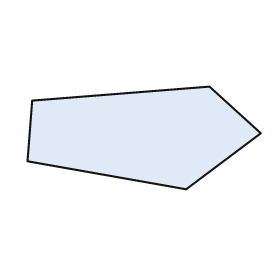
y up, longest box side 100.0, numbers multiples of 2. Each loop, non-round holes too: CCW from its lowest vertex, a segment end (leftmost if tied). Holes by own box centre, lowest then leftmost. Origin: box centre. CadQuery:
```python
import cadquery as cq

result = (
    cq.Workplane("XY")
    .moveTo(18.0, -22.0)
    .lineTo(50.0, 2.0)
    .lineTo(28.0, 22.0)
    .lineTo(-48.0, 16.0)
    .lineTo(-50.0, -10.0)
    .close()
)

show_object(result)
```